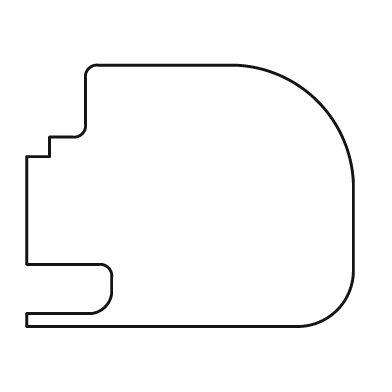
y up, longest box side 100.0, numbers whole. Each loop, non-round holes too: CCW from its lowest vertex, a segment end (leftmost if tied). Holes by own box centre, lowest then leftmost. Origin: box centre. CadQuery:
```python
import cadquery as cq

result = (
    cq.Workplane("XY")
    .moveTo(-50.0, -40.0)
    .lineTo(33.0, -40.0)
    .threePointArc((45.0, -35.0), (50.0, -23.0))
    .lineTo(50.0, 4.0)
    .threePointArc((39.0, 29.0), (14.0, 40.0))
    .lineTo(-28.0, 40.0)
    .threePointArc((-31.0, 39.0), (-32.0, 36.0))
    .lineTo(-32.0, 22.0)
    .threePointArc((-33.0, 19.0), (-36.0, 18.0))
    .lineTo(-43.0, 18.0)
    .lineTo(-43.0, 12.0)
    .lineTo(-50.0, 12.0)
    .lineTo(-50.0, -21.0)
    .lineTo(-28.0, -21.0)
    .threePointArc((-25.0, -22.0), (-24.0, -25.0))
    .lineTo(-24.0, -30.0)
    .threePointArc((-26.0, -34.0), (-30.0, -36.0))
    .lineTo(-50.0, -36.0)
    .close()
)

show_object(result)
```